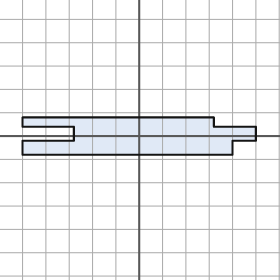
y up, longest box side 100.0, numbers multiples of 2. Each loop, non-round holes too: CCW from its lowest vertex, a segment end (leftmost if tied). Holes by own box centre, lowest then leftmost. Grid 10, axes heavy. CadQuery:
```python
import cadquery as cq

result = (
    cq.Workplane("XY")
    .moveTo(-50.0, -8.0)
    .lineTo(40.0, -8.0)
    .lineTo(40.0, -2.0)
    .lineTo(50.0, -2.0)
    .lineTo(50.0, 4.0)
    .lineTo(32.0, 4.0)
    .lineTo(32.0, 8.0)
    .lineTo(-50.0, 8.0)
    .lineTo(-50.0, 4.0)
    .lineTo(-28.0, 4.0)
    .lineTo(-28.0, -2.0)
    .lineTo(-50.0, -2.0)
    .close()
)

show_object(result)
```